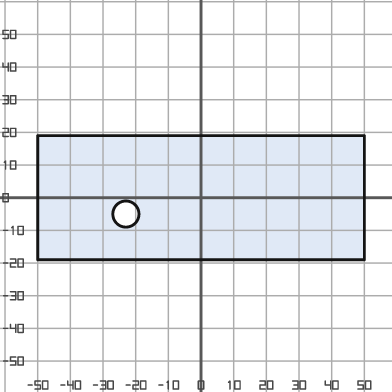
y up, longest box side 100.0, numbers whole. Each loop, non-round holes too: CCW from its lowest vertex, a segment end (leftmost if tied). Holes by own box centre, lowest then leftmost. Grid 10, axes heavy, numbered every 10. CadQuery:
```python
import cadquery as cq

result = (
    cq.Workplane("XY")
    .moveTo(-50.0, -19.0)
    .lineTo(50.0, -19.0)
    .lineTo(50.0, 19.0)
    .lineTo(-50.0, 19.0)
    .close()
    .moveTo(-23.0, -5.0)
    .circle(4.0)
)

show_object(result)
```